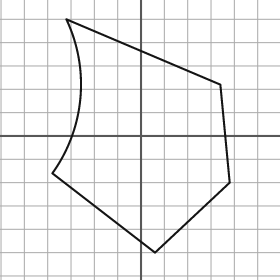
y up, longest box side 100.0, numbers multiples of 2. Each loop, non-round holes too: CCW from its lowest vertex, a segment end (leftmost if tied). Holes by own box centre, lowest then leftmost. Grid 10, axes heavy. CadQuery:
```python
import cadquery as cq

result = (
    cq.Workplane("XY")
    .moveTo(6.0, -50.0)
    .lineTo(38.0, -20.0)
    .lineTo(34.0, 22.0)
    .lineTo(-32.0, 50.0)
    .threePointArc((-26.0, 16.0), (-38.0, -16.0))
    .close()
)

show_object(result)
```